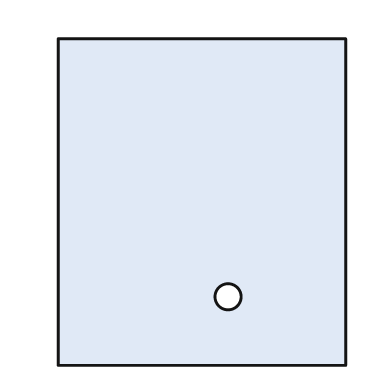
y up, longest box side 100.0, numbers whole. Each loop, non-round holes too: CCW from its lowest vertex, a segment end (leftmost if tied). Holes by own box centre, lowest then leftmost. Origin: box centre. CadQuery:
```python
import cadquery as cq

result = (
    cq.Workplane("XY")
    .moveTo(-44.0, -50.0)
    .lineTo(44.0, -50.0)
    .lineTo(44.0, 50.0)
    .lineTo(-44.0, 50.0)
    .close()
    .moveTo(8.0, -29.0)
    .circle(4.0)
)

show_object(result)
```